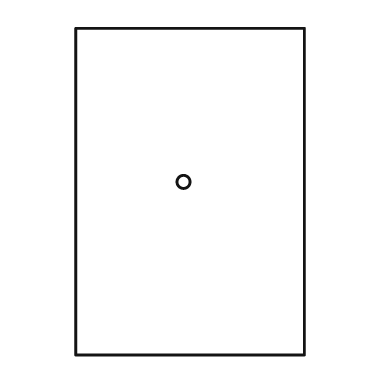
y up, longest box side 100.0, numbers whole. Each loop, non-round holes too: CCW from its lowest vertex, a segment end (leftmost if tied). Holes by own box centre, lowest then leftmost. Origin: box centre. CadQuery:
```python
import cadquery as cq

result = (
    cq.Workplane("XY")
    .moveTo(-35.0, -50.0)
    .lineTo(35.0, -50.0)
    .lineTo(35.0, 50.0)
    .lineTo(-35.0, 50.0)
    .close()
    .moveTo(-2.0, 3.0)
    .circle(2.0)
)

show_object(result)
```